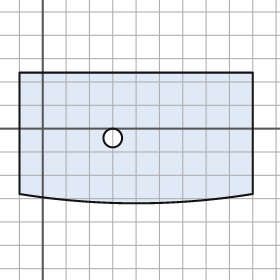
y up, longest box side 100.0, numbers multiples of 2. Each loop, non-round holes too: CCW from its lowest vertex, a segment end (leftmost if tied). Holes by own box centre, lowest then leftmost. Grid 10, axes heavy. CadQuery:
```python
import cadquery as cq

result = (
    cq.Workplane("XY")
    .moveTo(-10.0, -28.0)
    .threePointArc((40.0, -32.0), (90.0, -28.0))
    .lineTo(90.0, 24.0)
    .lineTo(-10.0, 24.0)
    .close()
    .moveTo(30.0, -4.0)
    .circle(4.0)
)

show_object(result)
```